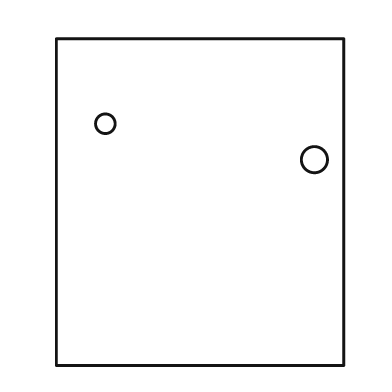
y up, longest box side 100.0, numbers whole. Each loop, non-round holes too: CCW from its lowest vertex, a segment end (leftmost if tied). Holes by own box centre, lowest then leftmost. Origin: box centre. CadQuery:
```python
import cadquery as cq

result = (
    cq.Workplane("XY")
    .moveTo(-44.0, -50.0)
    .lineTo(44.0, -50.0)
    .lineTo(44.0, 50.0)
    .lineTo(-44.0, 50.0)
    .close()
    .moveTo(35.0, 13.0)
    .circle(4.0)
    .moveTo(-29.0, 24.0)
    .circle(3.0)
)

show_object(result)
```